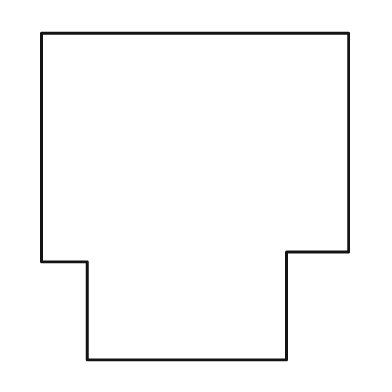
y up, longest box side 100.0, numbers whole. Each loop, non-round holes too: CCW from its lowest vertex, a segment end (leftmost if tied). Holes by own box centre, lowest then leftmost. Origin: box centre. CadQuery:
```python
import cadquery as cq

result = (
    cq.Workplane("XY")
    .moveTo(-33.0, -50.0)
    .lineTo(28.0, -50.0)
    .lineTo(28.0, -17.0)
    .lineTo(47.0, -17.0)
    .lineTo(47.0, 50.0)
    .lineTo(-47.0, 50.0)
    .lineTo(-47.0, -20.0)
    .lineTo(-33.0, -20.0)
    .close()
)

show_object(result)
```